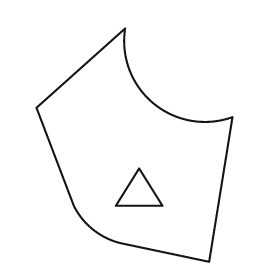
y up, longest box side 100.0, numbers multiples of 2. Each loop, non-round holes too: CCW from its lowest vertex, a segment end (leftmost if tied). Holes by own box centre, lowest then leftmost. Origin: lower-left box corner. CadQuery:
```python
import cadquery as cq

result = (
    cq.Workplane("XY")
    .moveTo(74.0, 0.0)
    .lineTo(84.0, 62.0)
    .threePointArc((50.0, 68.0), (38.0, 100.0))
    .lineTo(0.0, 66.0)
    .lineTo(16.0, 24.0)
    .threePointArc((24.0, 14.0), (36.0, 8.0))
    .close()
    .moveTo(34.0, 24.0)
    .lineTo(54.0, 24.0)
    .lineTo(44.0, 40.0)
    .close()
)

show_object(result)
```